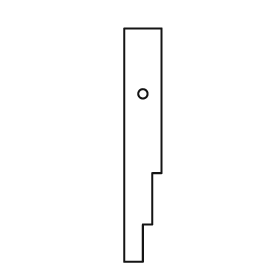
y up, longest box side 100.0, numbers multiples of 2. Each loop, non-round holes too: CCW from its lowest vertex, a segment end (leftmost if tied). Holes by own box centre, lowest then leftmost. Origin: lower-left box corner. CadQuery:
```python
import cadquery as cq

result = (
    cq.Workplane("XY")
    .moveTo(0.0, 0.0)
    .lineTo(8.0, 0.0)
    .lineTo(8.0, 16.0)
    .lineTo(12.0, 16.0)
    .lineTo(12.0, 38.0)
    .lineTo(16.0, 38.0)
    .lineTo(16.0, 100.0)
    .lineTo(0.0, 100.0)
    .close()
    .moveTo(8.0, 72.0)
    .circle(2.0)
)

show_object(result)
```